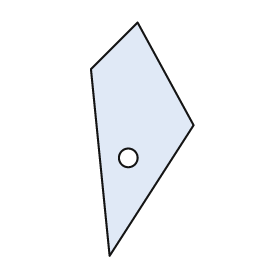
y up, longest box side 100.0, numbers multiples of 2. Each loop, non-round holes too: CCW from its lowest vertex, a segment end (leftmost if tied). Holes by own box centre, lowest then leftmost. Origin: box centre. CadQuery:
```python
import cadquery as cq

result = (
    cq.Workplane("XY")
    .moveTo(-14.0, -50.0)
    .lineTo(22.0, 6.0)
    .lineTo(-2.0, 50.0)
    .lineTo(-22.0, 30.0)
    .close()
    .moveTo(-6.0, -8.0)
    .circle(4.0)
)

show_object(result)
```